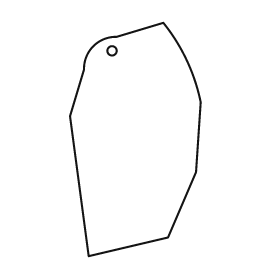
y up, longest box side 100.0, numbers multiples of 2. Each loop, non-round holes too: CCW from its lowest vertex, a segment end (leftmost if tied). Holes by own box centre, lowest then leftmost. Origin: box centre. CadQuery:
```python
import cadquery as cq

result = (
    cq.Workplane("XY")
    .moveTo(-20.0, -50.0)
    .lineTo(14.0, -42.0)
    .lineTo(26.0, -14.0)
    .lineTo(28.0, 16.0)
    .threePointArc((22.0, 34.0), (12.0, 50.0))
    .lineTo(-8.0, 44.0)
    .threePointArc((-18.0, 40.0), (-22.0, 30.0))
    .lineTo(-28.0, 10.0)
    .close()
    .moveTo(-10.0, 38.0)
    .circle(2.0)
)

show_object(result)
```